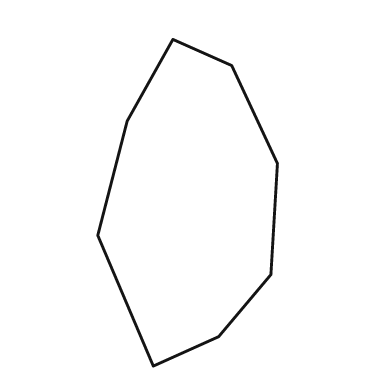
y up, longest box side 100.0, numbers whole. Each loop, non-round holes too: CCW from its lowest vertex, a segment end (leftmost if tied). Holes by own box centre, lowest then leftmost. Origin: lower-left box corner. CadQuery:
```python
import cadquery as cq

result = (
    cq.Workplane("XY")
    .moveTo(17.0, 0.0)
    .lineTo(37.0, 9.0)
    .lineTo(53.0, 28.0)
    .lineTo(55.0, 62.0)
    .lineTo(41.0, 92.0)
    .lineTo(23.0, 100.0)
    .lineTo(9.0, 75.0)
    .lineTo(0.0, 40.0)
    .close()
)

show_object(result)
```